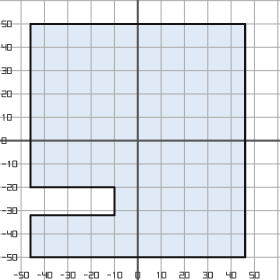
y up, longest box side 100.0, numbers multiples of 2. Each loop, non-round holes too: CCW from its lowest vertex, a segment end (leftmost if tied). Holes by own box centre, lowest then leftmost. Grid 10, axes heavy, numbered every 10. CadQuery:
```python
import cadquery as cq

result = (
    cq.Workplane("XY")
    .moveTo(-46.0, -50.0)
    .lineTo(46.0, -50.0)
    .lineTo(46.0, 50.0)
    .lineTo(-46.0, 50.0)
    .lineTo(-46.0, -20.0)
    .lineTo(-10.0, -20.0)
    .lineTo(-10.0, -32.0)
    .lineTo(-46.0, -32.0)
    .close()
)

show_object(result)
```